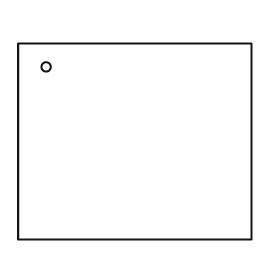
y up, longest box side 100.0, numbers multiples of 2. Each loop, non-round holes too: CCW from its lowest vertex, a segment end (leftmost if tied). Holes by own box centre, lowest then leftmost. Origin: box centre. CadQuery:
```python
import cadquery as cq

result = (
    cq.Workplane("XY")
    .moveTo(-50.0, -42.0)
    .lineTo(50.0, -42.0)
    .lineTo(50.0, 42.0)
    .lineTo(-50.0, 42.0)
    .close()
    .moveTo(-38.0, 32.0)
    .circle(2.0)
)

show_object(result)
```